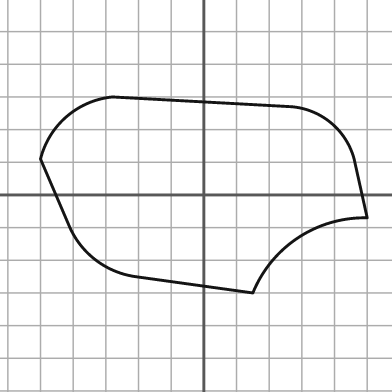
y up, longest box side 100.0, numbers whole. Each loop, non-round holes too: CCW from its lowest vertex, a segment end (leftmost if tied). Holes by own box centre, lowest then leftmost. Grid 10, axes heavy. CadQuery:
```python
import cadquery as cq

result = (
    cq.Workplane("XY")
    .moveTo(15.0, -30.0)
    .threePointArc((29.0, -13.0), (50.0, -7.0))
    .lineTo(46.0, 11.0)
    .threePointArc((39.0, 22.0), (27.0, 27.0))
    .lineTo(-28.0, 30.0)
    .threePointArc((-42.0, 24.0), (-50.0, 11.0))
    .lineTo(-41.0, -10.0)
    .threePointArc((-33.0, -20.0), (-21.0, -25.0))
    .close()
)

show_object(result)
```